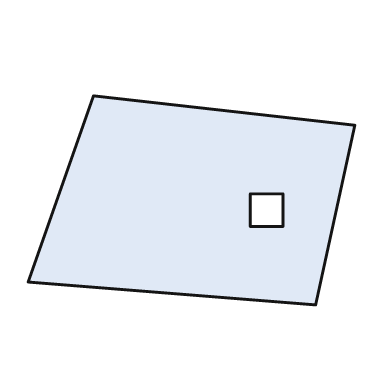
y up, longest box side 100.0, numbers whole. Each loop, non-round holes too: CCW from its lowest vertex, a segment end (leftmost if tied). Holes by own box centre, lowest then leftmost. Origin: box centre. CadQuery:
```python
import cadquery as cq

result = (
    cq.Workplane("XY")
    .moveTo(38.0, -32.0)
    .lineTo(50.0, 23.0)
    .lineTo(-30.0, 32.0)
    .lineTo(-50.0, -25.0)
    .close()
    .moveTo(18.0, -8.0)
    .lineTo(28.0, -8.0)
    .lineTo(28.0, 2.0)
    .lineTo(18.0, 2.0)
    .close()
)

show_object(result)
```